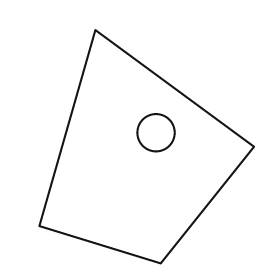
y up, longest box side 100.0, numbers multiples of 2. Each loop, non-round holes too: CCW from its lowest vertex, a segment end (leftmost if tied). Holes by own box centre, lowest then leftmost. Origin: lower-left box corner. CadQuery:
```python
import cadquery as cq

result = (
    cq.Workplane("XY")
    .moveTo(52.0, 0.0)
    .lineTo(92.0, 50.0)
    .lineTo(24.0, 100.0)
    .lineTo(0.0, 16.0)
    .close()
    .moveTo(50.0, 56.0)
    .circle(8.0)
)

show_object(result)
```